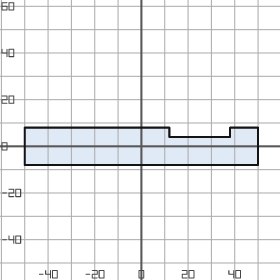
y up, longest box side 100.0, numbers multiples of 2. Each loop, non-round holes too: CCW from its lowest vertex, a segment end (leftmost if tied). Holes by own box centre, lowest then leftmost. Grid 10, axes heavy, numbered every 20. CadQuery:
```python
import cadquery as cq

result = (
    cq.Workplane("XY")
    .moveTo(-50.0, -8.0)
    .lineTo(50.0, -8.0)
    .lineTo(50.0, 8.0)
    .lineTo(38.0, 8.0)
    .lineTo(38.0, 4.0)
    .lineTo(12.0, 4.0)
    .lineTo(12.0, 8.0)
    .lineTo(-50.0, 8.0)
    .close()
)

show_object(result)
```